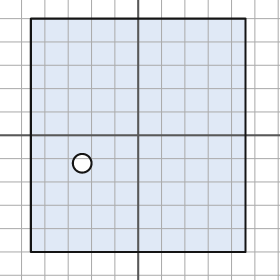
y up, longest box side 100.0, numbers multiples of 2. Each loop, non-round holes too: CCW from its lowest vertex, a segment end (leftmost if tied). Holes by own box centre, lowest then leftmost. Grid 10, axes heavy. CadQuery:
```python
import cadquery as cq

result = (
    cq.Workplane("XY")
    .moveTo(-46.0, -50.0)
    .lineTo(46.0, -50.0)
    .lineTo(46.0, 50.0)
    .lineTo(-46.0, 50.0)
    .close()
    .moveTo(-24.0, -12.0)
    .circle(4.0)
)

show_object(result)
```